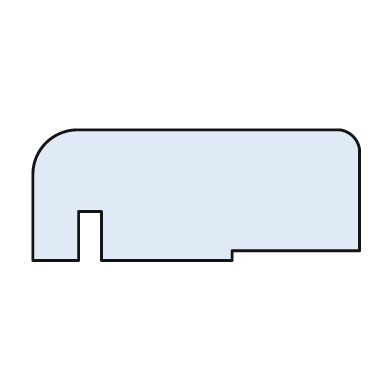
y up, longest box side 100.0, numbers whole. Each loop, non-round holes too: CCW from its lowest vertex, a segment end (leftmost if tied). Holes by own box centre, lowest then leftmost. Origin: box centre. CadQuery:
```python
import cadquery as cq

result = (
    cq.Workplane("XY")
    .moveTo(-50.0, -20.0)
    .lineTo(-36.0, -20.0)
    .lineTo(-36.0, -5.0)
    .lineTo(-29.0, -5.0)
    .lineTo(-29.0, -20.0)
    .lineTo(11.0, -20.0)
    .lineTo(11.0, -17.0)
    .lineTo(50.0, -17.0)
    .lineTo(50.0, 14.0)
    .threePointArc((48.0, 18.0), (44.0, 20.0))
    .lineTo(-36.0, 20.0)
    .threePointArc((-46.0, 16.0), (-50.0, 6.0))
    .close()
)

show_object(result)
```